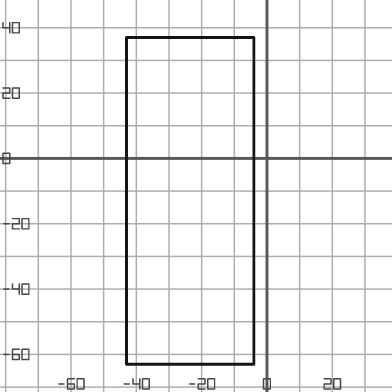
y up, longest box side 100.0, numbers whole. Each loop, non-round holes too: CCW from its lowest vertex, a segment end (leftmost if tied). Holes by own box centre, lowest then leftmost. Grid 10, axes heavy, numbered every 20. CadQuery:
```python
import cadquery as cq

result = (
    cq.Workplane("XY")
    .moveTo(-43.0, -63.0)
    .lineTo(-4.0, -63.0)
    .lineTo(-4.0, 37.0)
    .lineTo(-43.0, 37.0)
    .close()
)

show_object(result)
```